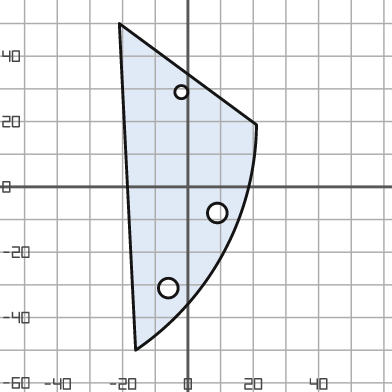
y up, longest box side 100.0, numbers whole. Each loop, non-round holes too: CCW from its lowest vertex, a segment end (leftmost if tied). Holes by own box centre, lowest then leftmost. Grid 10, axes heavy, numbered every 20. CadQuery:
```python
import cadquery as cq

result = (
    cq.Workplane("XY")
    .moveTo(-16.0, -50.0)
    .threePointArc((11.0, -20.0), (21.0, 19.0))
    .lineTo(-21.0, 50.0)
    .close()
    .moveTo(-6.0, -31.0)
    .circle(3.0)
    .moveTo(9.0, -8.0)
    .circle(3.0)
    .moveTo(-2.0, 29.0)
    .circle(2.0)
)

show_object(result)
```